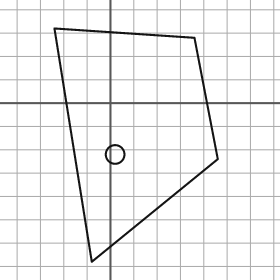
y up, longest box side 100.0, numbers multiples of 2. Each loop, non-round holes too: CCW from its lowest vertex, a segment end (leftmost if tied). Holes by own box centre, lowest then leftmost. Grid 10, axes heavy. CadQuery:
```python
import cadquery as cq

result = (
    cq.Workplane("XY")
    .moveTo(-8.0, -68.0)
    .lineTo(46.0, -24.0)
    .lineTo(36.0, 28.0)
    .lineTo(-24.0, 32.0)
    .close()
    .moveTo(2.0, -22.0)
    .circle(4.0)
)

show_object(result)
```